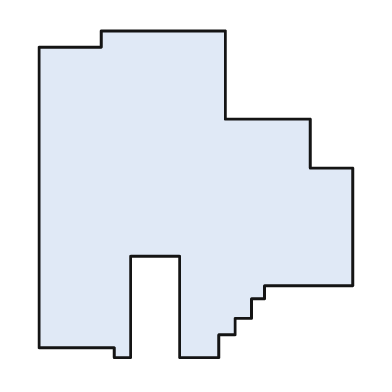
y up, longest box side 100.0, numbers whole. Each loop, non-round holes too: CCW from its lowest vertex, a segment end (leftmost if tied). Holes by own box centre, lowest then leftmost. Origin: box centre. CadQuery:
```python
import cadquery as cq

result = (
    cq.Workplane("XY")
    .moveTo(-25.0, -50.0)
    .lineTo(-20.0, -50.0)
    .lineTo(-20.0, -19.0)
    .lineTo(-5.0, -19.0)
    .lineTo(-5.0, -50.0)
    .lineTo(7.0, -50.0)
    .lineTo(7.0, -43.0)
    .lineTo(12.0, -43.0)
    .lineTo(12.0, -38.0)
    .lineTo(17.0, -38.0)
    .lineTo(17.0, -32.0)
    .lineTo(21.0, -32.0)
    .lineTo(21.0, -28.0)
    .lineTo(48.0, -28.0)
    .lineTo(48.0, 8.0)
    .lineTo(35.0, 8.0)
    .lineTo(35.0, 23.0)
    .lineTo(9.0, 23.0)
    .lineTo(9.0, 50.0)
    .lineTo(-29.0, 50.0)
    .lineTo(-29.0, 45.0)
    .lineTo(-48.0, 45.0)
    .lineTo(-48.0, -47.0)
    .lineTo(-25.0, -47.0)
    .close()
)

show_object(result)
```